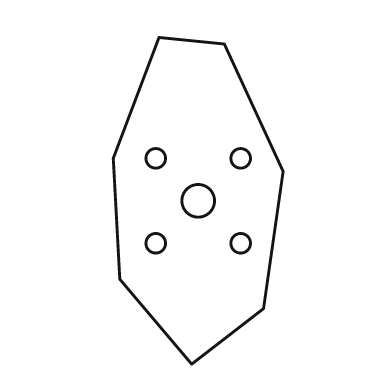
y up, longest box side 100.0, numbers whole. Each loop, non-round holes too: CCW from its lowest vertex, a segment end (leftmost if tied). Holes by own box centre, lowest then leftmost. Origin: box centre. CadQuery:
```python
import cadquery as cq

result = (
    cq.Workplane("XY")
    .moveTo(-2.0, -50.0)
    .lineTo(20.0, -33.0)
    .lineTo(26.0, 9.0)
    .lineTo(8.0, 48.0)
    .lineTo(-12.0, 50.0)
    .lineTo(-26.0, 13.0)
    .lineTo(-24.0, -24.0)
    .close()
    .moveTo(-13.0, -13.0)
    .circle(3.0)
    .moveTo(13.0, -13.0)
    .circle(3.0)
    .moveTo(0.0, 0.0)
    .circle(5.0)
    .moveTo(-13.0, 13.0)
    .circle(3.0)
    .moveTo(13.0, 13.0)
    .circle(3.0)
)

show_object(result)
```